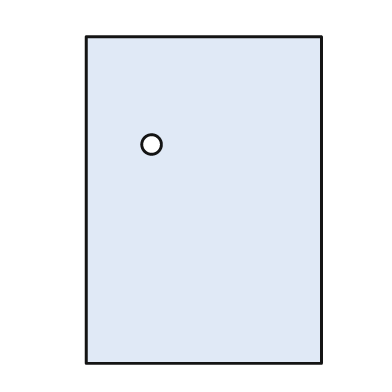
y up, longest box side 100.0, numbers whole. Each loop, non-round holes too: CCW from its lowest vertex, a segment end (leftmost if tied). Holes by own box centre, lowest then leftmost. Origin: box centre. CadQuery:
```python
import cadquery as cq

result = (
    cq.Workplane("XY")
    .moveTo(-36.0, -50.0)
    .lineTo(36.0, -50.0)
    .lineTo(36.0, 50.0)
    .lineTo(-36.0, 50.0)
    .close()
    .moveTo(-16.0, 17.0)
    .circle(3.0)
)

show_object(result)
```